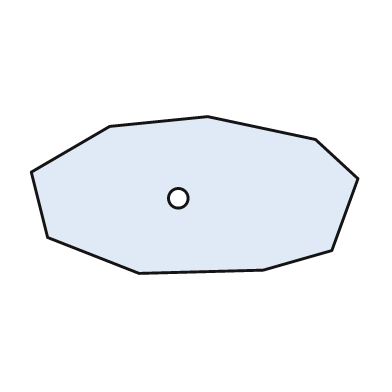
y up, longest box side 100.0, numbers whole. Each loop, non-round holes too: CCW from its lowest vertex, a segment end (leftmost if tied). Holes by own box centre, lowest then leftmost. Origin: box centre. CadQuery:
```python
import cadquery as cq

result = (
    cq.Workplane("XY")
    .moveTo(-17.0, -24.0)
    .lineTo(21.0, -23.0)
    .lineTo(42.0, -17.0)
    .lineTo(50.0, 5.0)
    .lineTo(37.0, 17.0)
    .lineTo(4.0, 24.0)
    .lineTo(-26.0, 21.0)
    .lineTo(-50.0, 7.0)
    .lineTo(-45.0, -13.0)
    .close()
    .moveTo(-5.0, -1.0)
    .circle(3.0)
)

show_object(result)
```